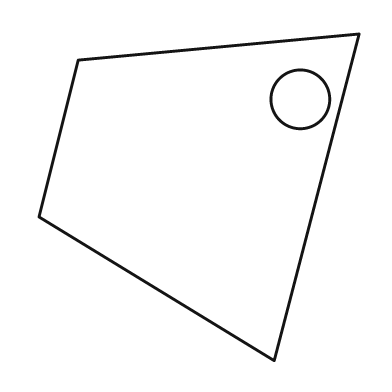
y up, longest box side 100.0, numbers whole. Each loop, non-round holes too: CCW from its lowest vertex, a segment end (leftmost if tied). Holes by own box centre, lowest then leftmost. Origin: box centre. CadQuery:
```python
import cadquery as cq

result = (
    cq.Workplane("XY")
    .moveTo(23.0, -50.0)
    .lineTo(49.0, 50.0)
    .lineTo(-37.0, 42.0)
    .lineTo(-49.0, -6.0)
    .close()
    .moveTo(31.0, 30.0)
    .circle(9.0)
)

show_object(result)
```